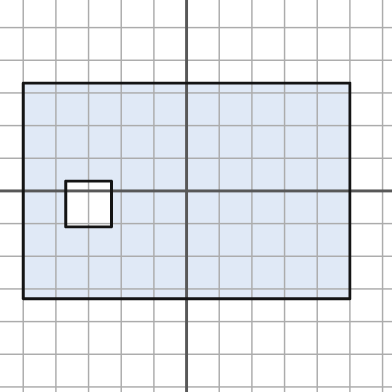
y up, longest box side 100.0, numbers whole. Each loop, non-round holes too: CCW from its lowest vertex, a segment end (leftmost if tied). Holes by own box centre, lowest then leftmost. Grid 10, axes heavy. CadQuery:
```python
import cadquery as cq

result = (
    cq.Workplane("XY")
    .moveTo(-50.0, -33.0)
    .lineTo(50.0, -33.0)
    .lineTo(50.0, 33.0)
    .lineTo(-50.0, 33.0)
    .close()
    .moveTo(-37.0, -11.0)
    .lineTo(-23.0, -11.0)
    .lineTo(-23.0, 3.0)
    .lineTo(-37.0, 3.0)
    .close()
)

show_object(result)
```